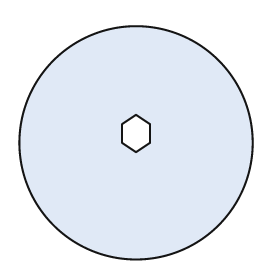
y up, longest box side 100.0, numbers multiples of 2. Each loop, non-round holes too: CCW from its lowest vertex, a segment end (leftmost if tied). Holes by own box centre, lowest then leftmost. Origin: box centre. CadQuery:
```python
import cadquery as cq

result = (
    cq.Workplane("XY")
    .moveTo(0.0, 0.0)
    .circle(50.0)
    .moveTo(0.0, -4.0)
    .lineTo(6.0, 0.0)
    .lineTo(6.0, 8.0)
    .lineTo(0.0, 12.0)
    .lineTo(-6.0, 8.0)
    .lineTo(-6.0, 0.0)
    .close()
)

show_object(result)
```